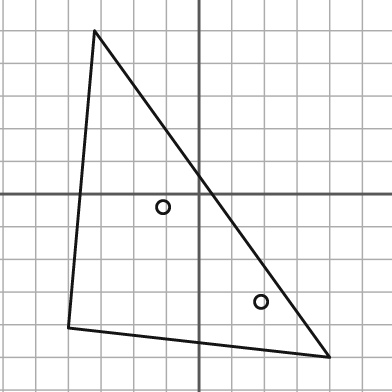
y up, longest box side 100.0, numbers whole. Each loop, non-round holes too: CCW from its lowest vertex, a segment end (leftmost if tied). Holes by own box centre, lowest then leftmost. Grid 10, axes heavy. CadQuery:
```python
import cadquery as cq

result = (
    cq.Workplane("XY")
    .moveTo(40.0, -50.0)
    .lineTo(-32.0, 50.0)
    .lineTo(-40.0, -41.0)
    .close()
    .moveTo(19.0, -33.0)
    .circle(2.0)
    .moveTo(-11.0, -4.0)
    .circle(2.0)
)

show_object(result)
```